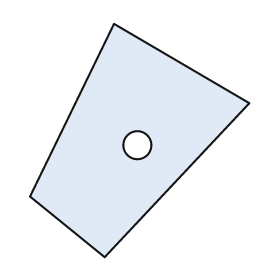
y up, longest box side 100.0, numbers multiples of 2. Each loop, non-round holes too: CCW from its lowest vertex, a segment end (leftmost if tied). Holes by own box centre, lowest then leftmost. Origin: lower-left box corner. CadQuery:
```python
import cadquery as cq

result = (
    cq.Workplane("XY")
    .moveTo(32.0, 0.0)
    .lineTo(94.0, 66.0)
    .lineTo(36.0, 100.0)
    .lineTo(0.0, 26.0)
    .close()
    .moveTo(46.0, 48.0)
    .circle(6.0)
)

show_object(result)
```